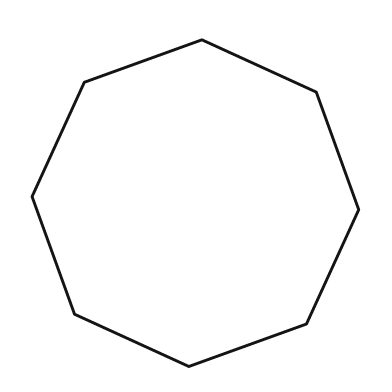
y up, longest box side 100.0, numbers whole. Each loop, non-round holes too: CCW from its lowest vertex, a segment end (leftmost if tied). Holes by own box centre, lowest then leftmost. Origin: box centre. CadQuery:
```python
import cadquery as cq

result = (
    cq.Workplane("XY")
    .moveTo(-2.0, -50.0)
    .lineTo(34.0, -37.0)
    .lineTo(50.0, -2.0)
    .lineTo(37.0, 34.0)
    .lineTo(2.0, 50.0)
    .lineTo(-34.0, 37.0)
    .lineTo(-50.0, 2.0)
    .lineTo(-37.0, -34.0)
    .close()
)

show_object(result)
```